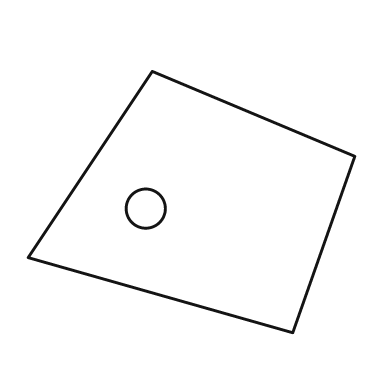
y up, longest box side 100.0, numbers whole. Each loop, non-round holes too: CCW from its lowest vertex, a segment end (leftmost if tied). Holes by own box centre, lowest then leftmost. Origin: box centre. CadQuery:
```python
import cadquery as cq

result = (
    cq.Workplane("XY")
    .moveTo(31.0, -40.0)
    .lineTo(50.0, 14.0)
    .lineTo(-12.0, 40.0)
    .lineTo(-50.0, -17.0)
    .close()
    .moveTo(-14.0, -2.0)
    .circle(6.0)
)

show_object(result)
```